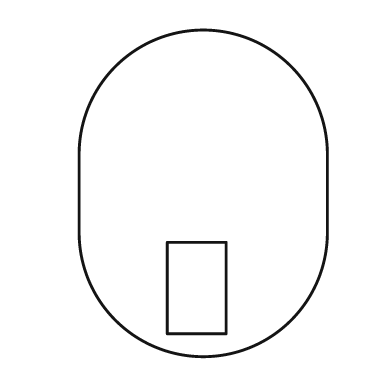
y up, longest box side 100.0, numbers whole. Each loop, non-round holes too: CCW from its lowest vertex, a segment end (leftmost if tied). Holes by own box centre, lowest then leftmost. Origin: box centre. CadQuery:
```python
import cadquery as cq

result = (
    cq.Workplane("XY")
    .moveTo(-38.0, -12.0)
    .threePointArc((0.0, -50.0), (38.0, -12.0))
    .lineTo(38.0, 12.0)
    .threePointArc((0.0, 50.0), (-38.0, 12.0))
    .close()
    .moveTo(-11.0, -43.0)
    .lineTo(7.0, -43.0)
    .lineTo(7.0, -15.0)
    .lineTo(-11.0, -15.0)
    .close()
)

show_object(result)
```